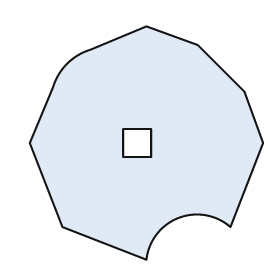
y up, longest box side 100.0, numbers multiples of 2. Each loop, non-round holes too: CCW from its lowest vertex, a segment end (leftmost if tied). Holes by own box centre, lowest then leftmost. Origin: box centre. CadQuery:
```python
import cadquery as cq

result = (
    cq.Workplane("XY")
    .moveTo(0.0, -50.0)
    .threePointArc((14.0, -32.0), (36.0, -36.0))
    .lineTo(50.0, 0.0)
    .lineTo(42.0, 22.0)
    .lineTo(22.0, 42.0)
    .lineTo(0.0, 50.0)
    .lineTo(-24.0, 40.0)
    .threePointArc((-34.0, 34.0), (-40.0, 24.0))
    .lineTo(-50.0, 0.0)
    .lineTo(-36.0, -36.0)
    .close()
    .moveTo(-10.0, -6.0)
    .lineTo(2.0, -6.0)
    .lineTo(2.0, 6.0)
    .lineTo(-10.0, 6.0)
    .close()
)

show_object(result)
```